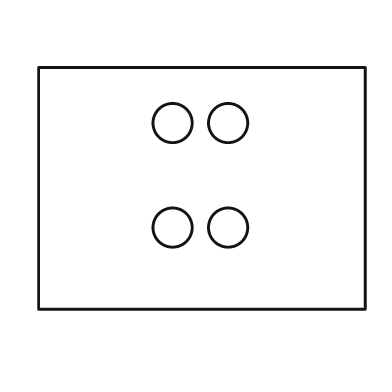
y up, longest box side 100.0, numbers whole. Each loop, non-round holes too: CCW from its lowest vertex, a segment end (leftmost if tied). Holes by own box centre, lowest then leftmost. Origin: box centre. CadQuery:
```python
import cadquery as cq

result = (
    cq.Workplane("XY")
    .moveTo(-50.0, -37.0)
    .lineTo(50.0, -37.0)
    .lineTo(50.0, 37.0)
    .lineTo(-50.0, 37.0)
    .close()
    .moveTo(-9.0, -12.0)
    .circle(6.0)
    .moveTo(8.0, -12.0)
    .circle(6.0)
    .moveTo(-9.0, 20.0)
    .circle(6.0)
    .moveTo(8.0, 20.0)
    .circle(6.0)
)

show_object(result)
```